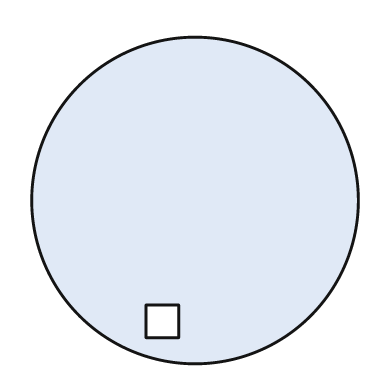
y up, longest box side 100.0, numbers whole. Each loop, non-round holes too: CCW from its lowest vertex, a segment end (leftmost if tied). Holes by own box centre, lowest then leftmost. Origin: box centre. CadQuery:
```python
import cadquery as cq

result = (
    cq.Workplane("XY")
    .moveTo(0.0, 0.0)
    .circle(50.0)
    .moveTo(-15.0, -42.0)
    .lineTo(-5.0, -42.0)
    .lineTo(-5.0, -32.0)
    .lineTo(-15.0, -32.0)
    .close()
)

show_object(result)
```